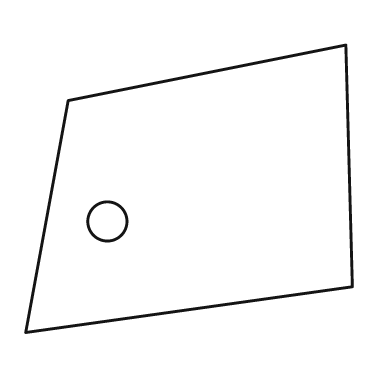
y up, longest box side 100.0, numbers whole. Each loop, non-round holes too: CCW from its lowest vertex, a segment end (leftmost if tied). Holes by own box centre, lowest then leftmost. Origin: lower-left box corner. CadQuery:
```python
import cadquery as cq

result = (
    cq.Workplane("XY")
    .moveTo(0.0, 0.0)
    .lineTo(100.0, 14.0)
    .lineTo(98.0, 88.0)
    .lineTo(13.0, 71.0)
    .close()
    .moveTo(25.0, 34.0)
    .circle(6.0)
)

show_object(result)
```